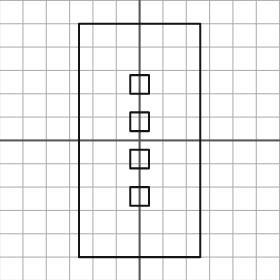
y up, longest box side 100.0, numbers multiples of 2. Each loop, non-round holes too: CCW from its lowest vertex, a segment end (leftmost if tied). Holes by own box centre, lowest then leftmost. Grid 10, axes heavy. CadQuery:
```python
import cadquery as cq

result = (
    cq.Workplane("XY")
    .moveTo(-26.0, -50.0)
    .lineTo(26.0, -50.0)
    .lineTo(26.0, 50.0)
    .lineTo(-26.0, 50.0)
    .close()
    .moveTo(-4.0, -28.0)
    .lineTo(4.0, -28.0)
    .lineTo(4.0, -20.0)
    .lineTo(-4.0, -20.0)
    .close()
    .moveTo(-4.0, -12.0)
    .lineTo(4.0, -12.0)
    .lineTo(4.0, -4.0)
    .lineTo(-4.0, -4.0)
    .close()
    .moveTo(-4.0, 4.0)
    .lineTo(4.0, 4.0)
    .lineTo(4.0, 12.0)
    .lineTo(-4.0, 12.0)
    .close()
    .moveTo(-4.0, 20.0)
    .lineTo(4.0, 20.0)
    .lineTo(4.0, 28.0)
    .lineTo(-4.0, 28.0)
    .close()
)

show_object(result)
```